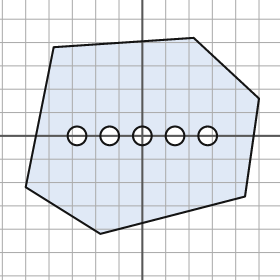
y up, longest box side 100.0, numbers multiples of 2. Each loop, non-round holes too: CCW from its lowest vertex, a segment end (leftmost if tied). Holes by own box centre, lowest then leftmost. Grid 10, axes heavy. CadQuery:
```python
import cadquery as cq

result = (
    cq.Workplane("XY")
    .moveTo(-18.0, -42.0)
    .lineTo(44.0, -26.0)
    .lineTo(50.0, 16.0)
    .lineTo(22.0, 42.0)
    .lineTo(-38.0, 38.0)
    .lineTo(-50.0, -22.0)
    .close()
    .moveTo(-28.0, 0.0)
    .circle(4.0)
    .moveTo(-14.0, 0.0)
    .circle(4.0)
    .moveTo(0.0, 0.0)
    .circle(4.0)
    .moveTo(14.0, 0.0)
    .circle(4.0)
    .moveTo(28.0, 0.0)
    .circle(4.0)
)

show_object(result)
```